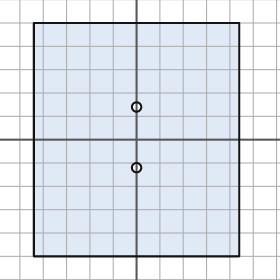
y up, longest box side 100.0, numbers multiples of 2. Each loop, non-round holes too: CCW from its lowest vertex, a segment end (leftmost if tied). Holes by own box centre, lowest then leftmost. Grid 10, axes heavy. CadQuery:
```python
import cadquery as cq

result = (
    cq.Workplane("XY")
    .moveTo(-44.0, -50.0)
    .lineTo(44.0, -50.0)
    .lineTo(44.0, 50.0)
    .lineTo(-44.0, 50.0)
    .close()
    .moveTo(0.0, -12.0)
    .circle(2.0)
    .moveTo(0.0, 14.0)
    .circle(2.0)
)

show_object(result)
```